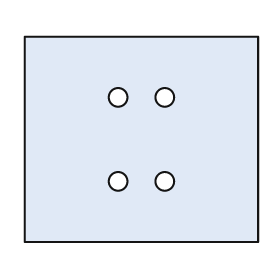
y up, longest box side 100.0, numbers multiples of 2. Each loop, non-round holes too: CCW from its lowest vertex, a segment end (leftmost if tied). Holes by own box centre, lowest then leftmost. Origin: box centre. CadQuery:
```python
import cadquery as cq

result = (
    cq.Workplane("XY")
    .moveTo(-50.0, -44.0)
    .lineTo(50.0, -44.0)
    .lineTo(50.0, 44.0)
    .lineTo(-50.0, 44.0)
    .close()
    .moveTo(-10.0, -18.0)
    .circle(4.0)
    .moveTo(10.0, -18.0)
    .circle(4.0)
    .moveTo(-10.0, 18.0)
    .circle(4.0)
    .moveTo(10.0, 18.0)
    .circle(4.0)
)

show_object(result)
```